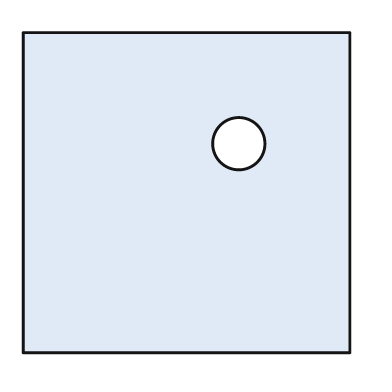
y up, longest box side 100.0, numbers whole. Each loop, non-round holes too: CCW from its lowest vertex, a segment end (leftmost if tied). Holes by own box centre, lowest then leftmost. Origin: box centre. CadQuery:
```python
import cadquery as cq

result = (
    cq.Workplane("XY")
    .moveTo(-50.0, -49.0)
    .lineTo(50.0, -49.0)
    .lineTo(50.0, 49.0)
    .lineTo(-50.0, 49.0)
    .close()
    .moveTo(16.0, 15.0)
    .circle(8.0)
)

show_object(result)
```